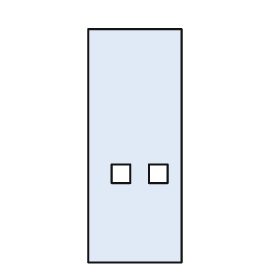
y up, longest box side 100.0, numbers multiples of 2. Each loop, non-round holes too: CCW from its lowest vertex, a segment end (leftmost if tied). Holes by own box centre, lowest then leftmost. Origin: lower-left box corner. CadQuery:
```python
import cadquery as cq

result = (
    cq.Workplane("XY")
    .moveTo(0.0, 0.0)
    .lineTo(40.0, 0.0)
    .lineTo(40.0, 100.0)
    .lineTo(0.0, 100.0)
    .close()
    .moveTo(10.0, 34.0)
    .lineTo(18.0, 34.0)
    .lineTo(18.0, 42.0)
    .lineTo(10.0, 42.0)
    .close()
    .moveTo(26.0, 34.0)
    .lineTo(34.0, 34.0)
    .lineTo(34.0, 42.0)
    .lineTo(26.0, 42.0)
    .close()
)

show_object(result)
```